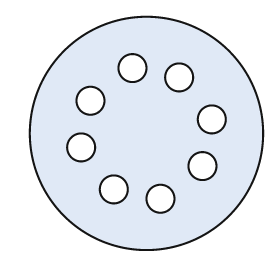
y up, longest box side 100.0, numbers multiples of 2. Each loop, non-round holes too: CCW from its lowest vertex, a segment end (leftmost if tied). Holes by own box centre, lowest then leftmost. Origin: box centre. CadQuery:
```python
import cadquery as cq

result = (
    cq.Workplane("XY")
    .moveTo(0.0, 0.0)
    .circle(50.0)
    .moveTo(6.0, -28.0)
    .circle(6.0)
    .moveTo(-14.0, -24.0)
    .circle(6.0)
    .moveTo(24.0, -14.0)
    .circle(6.0)
    .moveTo(-28.0, -6.0)
    .circle(6.0)
    .moveTo(28.0, 6.0)
    .circle(6.0)
    .moveTo(-24.0, 14.0)
    .circle(6.0)
    .moveTo(14.0, 24.0)
    .circle(6.0)
    .moveTo(-6.0, 28.0)
    .circle(6.0)
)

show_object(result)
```